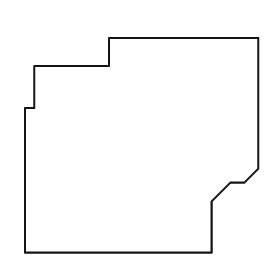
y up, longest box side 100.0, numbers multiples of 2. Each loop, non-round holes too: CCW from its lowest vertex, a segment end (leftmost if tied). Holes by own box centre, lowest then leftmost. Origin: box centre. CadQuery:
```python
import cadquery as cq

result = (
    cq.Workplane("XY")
    .moveTo(-50.0, -46.0)
    .lineTo(30.0, -46.0)
    .lineTo(30.0, -24.0)
    .lineTo(38.0, -16.0)
    .lineTo(44.0, -16.0)
    .lineTo(50.0, -10.0)
    .lineTo(50.0, 46.0)
    .lineTo(-14.0, 46.0)
    .lineTo(-14.0, 34.0)
    .lineTo(-46.0, 34.0)
    .lineTo(-46.0, 16.0)
    .lineTo(-50.0, 16.0)
    .close()
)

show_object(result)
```